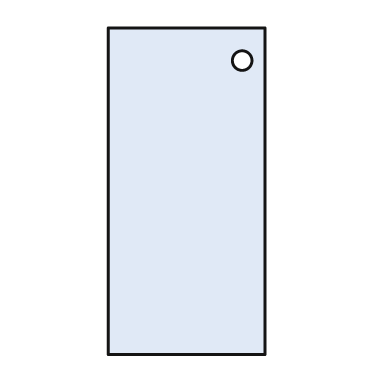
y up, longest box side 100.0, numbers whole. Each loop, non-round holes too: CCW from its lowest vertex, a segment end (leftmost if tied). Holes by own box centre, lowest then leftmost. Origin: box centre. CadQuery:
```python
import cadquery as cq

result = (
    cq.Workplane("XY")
    .moveTo(-24.0, -50.0)
    .lineTo(24.0, -50.0)
    .lineTo(24.0, 50.0)
    .lineTo(-24.0, 50.0)
    .close()
    .moveTo(17.0, 40.0)
    .circle(3.0)
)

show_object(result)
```